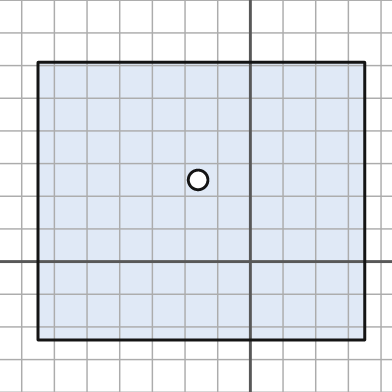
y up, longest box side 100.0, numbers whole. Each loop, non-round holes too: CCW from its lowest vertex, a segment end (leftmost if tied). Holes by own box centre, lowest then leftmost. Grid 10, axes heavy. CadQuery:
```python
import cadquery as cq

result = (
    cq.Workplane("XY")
    .moveTo(-65.0, -24.0)
    .lineTo(35.0, -24.0)
    .lineTo(35.0, 61.0)
    .lineTo(-65.0, 61.0)
    .close()
    .moveTo(-16.0, 25.0)
    .circle(3.0)
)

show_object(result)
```